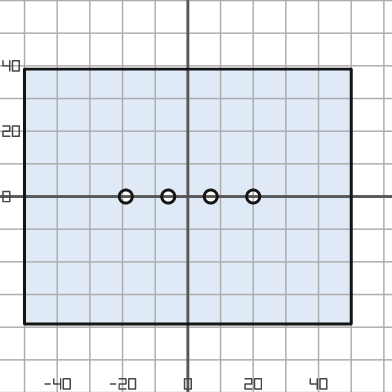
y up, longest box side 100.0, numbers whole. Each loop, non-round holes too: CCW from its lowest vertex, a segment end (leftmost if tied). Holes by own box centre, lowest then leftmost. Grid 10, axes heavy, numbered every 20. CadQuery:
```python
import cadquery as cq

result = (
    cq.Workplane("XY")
    .moveTo(-50.0, -39.0)
    .lineTo(50.0, -39.0)
    .lineTo(50.0, 39.0)
    .lineTo(-50.0, 39.0)
    .close()
    .moveTo(-19.0, 0.0)
    .circle(2.0)
    .moveTo(-6.0, 0.0)
    .circle(2.0)
    .moveTo(7.0, 0.0)
    .circle(2.0)
    .moveTo(20.0, 0.0)
    .circle(2.0)
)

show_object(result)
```